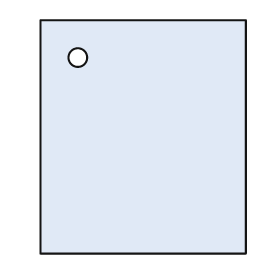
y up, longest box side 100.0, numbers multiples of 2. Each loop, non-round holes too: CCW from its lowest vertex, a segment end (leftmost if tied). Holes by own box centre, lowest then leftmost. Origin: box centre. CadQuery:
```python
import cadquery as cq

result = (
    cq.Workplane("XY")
    .moveTo(-44.0, -50.0)
    .lineTo(44.0, -50.0)
    .lineTo(44.0, 50.0)
    .lineTo(-44.0, 50.0)
    .close()
    .moveTo(-28.0, 34.0)
    .circle(4.0)
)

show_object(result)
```